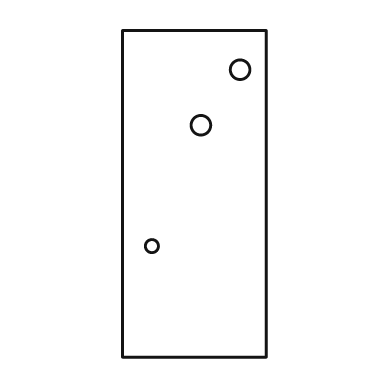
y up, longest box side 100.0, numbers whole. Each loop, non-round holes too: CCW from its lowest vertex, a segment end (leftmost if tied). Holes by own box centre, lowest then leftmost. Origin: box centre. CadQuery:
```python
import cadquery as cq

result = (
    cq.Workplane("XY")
    .moveTo(-22.0, -50.0)
    .lineTo(22.0, -50.0)
    .lineTo(22.0, 50.0)
    .lineTo(-22.0, 50.0)
    .close()
    .moveTo(-13.0, -16.0)
    .circle(2.0)
    .moveTo(2.0, 21.0)
    .circle(3.0)
    .moveTo(14.0, 38.0)
    .circle(3.0)
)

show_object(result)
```